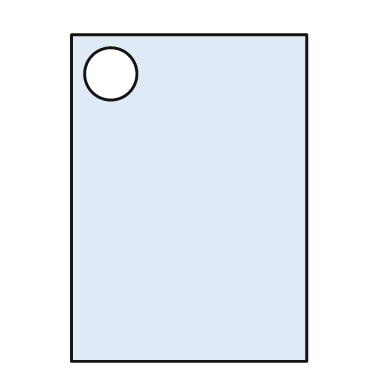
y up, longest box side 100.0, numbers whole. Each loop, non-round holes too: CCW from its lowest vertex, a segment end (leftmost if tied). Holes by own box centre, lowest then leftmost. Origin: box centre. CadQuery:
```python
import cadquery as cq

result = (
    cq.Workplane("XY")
    .moveTo(-36.0, -50.0)
    .lineTo(36.0, -50.0)
    .lineTo(36.0, 50.0)
    .lineTo(-36.0, 50.0)
    .close()
    .moveTo(-24.0, 38.0)
    .circle(8.0)
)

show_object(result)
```